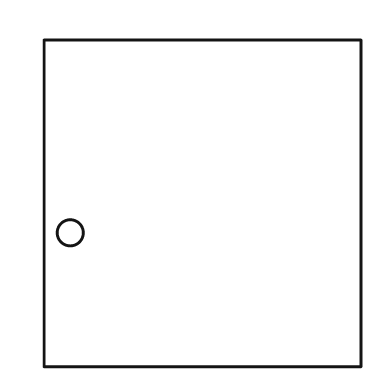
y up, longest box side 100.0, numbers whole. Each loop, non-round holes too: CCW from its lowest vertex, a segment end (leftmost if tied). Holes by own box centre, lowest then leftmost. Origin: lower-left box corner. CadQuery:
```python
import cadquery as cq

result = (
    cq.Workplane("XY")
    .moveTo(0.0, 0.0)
    .lineTo(97.0, 0.0)
    .lineTo(97.0, 100.0)
    .lineTo(0.0, 100.0)
    .close()
    .moveTo(8.0, 41.0)
    .circle(4.0)
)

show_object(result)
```